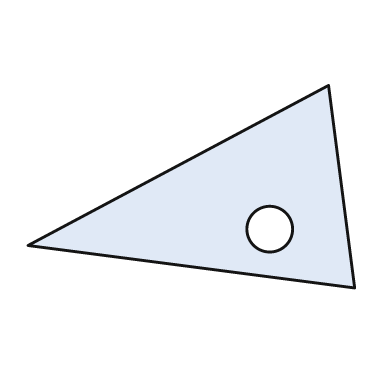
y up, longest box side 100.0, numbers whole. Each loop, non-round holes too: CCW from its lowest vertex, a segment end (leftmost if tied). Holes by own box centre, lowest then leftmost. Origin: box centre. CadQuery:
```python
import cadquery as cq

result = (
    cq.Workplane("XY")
    .moveTo(50.0, -31.0)
    .lineTo(42.0, 31.0)
    .lineTo(-50.0, -18.0)
    .close()
    .moveTo(24.0, -13.0)
    .circle(7.0)
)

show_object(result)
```